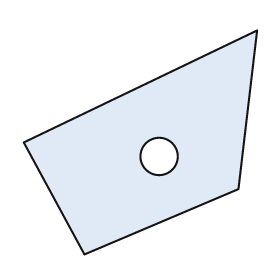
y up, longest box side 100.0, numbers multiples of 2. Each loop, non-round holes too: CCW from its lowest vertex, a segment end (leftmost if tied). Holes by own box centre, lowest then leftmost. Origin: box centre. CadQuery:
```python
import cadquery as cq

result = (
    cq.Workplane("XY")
    .moveTo(-24.0, -48.0)
    .lineTo(42.0, -20.0)
    .lineTo(50.0, 48.0)
    .lineTo(-50.0, 0.0)
    .close()
    .moveTo(8.0, -6.0)
    .circle(8.0)
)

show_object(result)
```